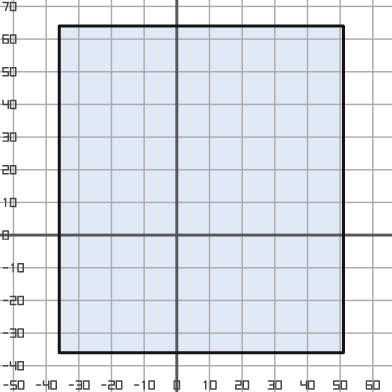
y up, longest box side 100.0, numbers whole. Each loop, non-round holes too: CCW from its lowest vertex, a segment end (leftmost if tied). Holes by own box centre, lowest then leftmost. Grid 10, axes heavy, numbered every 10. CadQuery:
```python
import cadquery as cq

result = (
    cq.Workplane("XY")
    .moveTo(-36.0, -36.0)
    .lineTo(51.0, -36.0)
    .lineTo(51.0, 64.0)
    .lineTo(-36.0, 64.0)
    .close()
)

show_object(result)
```